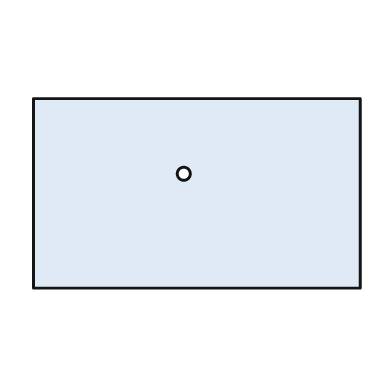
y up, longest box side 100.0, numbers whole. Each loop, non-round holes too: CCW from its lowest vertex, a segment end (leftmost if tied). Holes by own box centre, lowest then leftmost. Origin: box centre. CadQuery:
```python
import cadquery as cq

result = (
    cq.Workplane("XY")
    .moveTo(-50.0, -29.0)
    .lineTo(50.0, -29.0)
    .lineTo(50.0, 29.0)
    .lineTo(-50.0, 29.0)
    .close()
    .moveTo(-4.0, 6.0)
    .circle(2.0)
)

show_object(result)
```